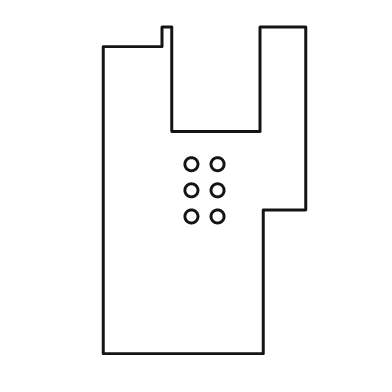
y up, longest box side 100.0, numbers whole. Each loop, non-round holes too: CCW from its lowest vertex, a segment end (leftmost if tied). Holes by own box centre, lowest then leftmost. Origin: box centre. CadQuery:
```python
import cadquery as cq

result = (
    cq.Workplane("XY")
    .moveTo(-31.0, -50.0)
    .lineTo(18.0, -50.0)
    .lineTo(18.0, -6.0)
    .lineTo(31.0, -6.0)
    .lineTo(31.0, 50.0)
    .lineTo(17.0, 50.0)
    .lineTo(17.0, 18.0)
    .lineTo(-10.0, 18.0)
    .lineTo(-10.0, 50.0)
    .lineTo(-13.0, 50.0)
    .lineTo(-13.0, 44.0)
    .lineTo(-31.0, 44.0)
    .close()
    .moveTo(-4.0, -8.0)
    .circle(2.0)
    .moveTo(4.0, -8.0)
    .circle(2.0)
    .moveTo(-4.0, 0.0)
    .circle(2.0)
    .moveTo(4.0, 0.0)
    .circle(2.0)
    .moveTo(-4.0, 8.0)
    .circle(2.0)
    .moveTo(4.0, 8.0)
    .circle(2.0)
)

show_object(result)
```